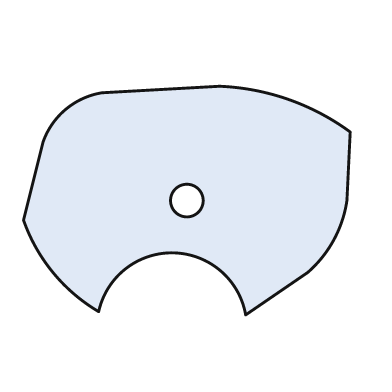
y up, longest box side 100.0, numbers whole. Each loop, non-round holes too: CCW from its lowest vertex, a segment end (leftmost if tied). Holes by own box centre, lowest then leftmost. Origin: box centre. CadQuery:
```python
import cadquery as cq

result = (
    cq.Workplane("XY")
    .moveTo(18.0, -35.0)
    .lineTo(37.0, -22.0)
    .threePointArc((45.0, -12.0), (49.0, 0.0))
    .lineTo(50.0, 21.0)
    .threePointArc((31.0, 31.0), (10.0, 35.0))
    .lineTo(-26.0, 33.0)
    .threePointArc((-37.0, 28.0), (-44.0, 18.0))
    .lineTo(-50.0, -6.0)
    .threePointArc((-41.0, -22.0), (-27.0, -34.0))
    .threePointArc((-4.0, -16.0), (18.0, -35.0))
    .close()
    .moveTo(0.0, 0.0)
    .circle(5.0)
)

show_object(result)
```